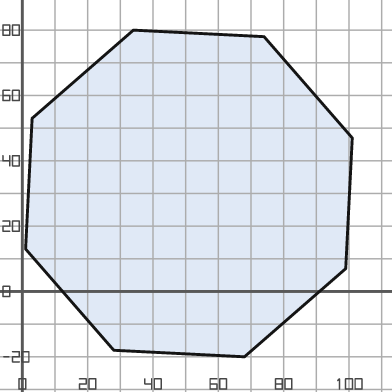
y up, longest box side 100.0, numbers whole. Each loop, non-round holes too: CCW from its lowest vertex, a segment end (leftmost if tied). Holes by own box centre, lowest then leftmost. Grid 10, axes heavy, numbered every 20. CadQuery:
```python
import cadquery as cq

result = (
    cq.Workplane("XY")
    .moveTo(68.0, -20.0)
    .lineTo(99.0, 7.0)
    .lineTo(101.0, 47.0)
    .lineTo(74.0, 78.0)
    .lineTo(34.0, 80.0)
    .lineTo(3.0, 53.0)
    .lineTo(1.0, 13.0)
    .lineTo(28.0, -18.0)
    .close()
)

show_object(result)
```